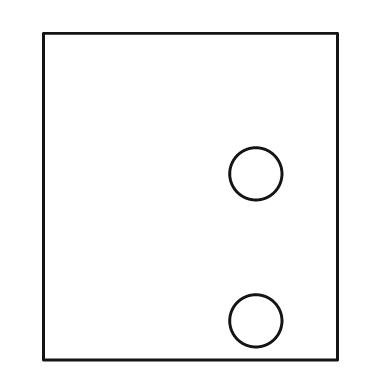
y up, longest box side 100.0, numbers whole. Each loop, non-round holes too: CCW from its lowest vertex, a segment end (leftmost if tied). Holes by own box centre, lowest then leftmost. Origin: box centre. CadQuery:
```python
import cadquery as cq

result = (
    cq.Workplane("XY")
    .moveTo(-45.0, -50.0)
    .lineTo(45.0, -50.0)
    .lineTo(45.0, 50.0)
    .lineTo(-45.0, 50.0)
    .close()
    .moveTo(20.0, -38.0)
    .circle(8.0)
    .moveTo(20.0, 7.0)
    .circle(8.0)
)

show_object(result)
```